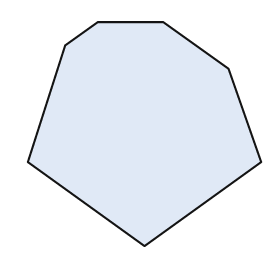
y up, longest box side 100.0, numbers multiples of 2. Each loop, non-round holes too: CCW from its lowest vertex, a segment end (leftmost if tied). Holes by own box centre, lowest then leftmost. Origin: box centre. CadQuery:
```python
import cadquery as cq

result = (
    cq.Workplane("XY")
    .moveTo(0.0, -48.0)
    .lineTo(50.0, -12.0)
    .lineTo(36.0, 28.0)
    .lineTo(8.0, 48.0)
    .lineTo(-20.0, 48.0)
    .lineTo(-34.0, 38.0)
    .lineTo(-50.0, -12.0)
    .close()
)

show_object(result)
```